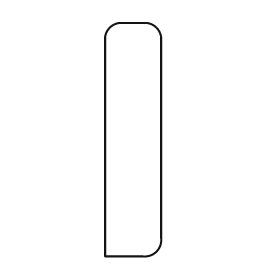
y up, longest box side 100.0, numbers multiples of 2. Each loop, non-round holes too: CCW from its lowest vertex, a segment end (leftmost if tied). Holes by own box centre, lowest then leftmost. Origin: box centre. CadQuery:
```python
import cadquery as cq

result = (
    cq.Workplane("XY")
    .moveTo(-12.0, -50.0)
    .lineTo(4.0, -50.0)
    .threePointArc((10.0, -48.0), (12.0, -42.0))
    .lineTo(12.0, 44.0)
    .threePointArc((10.0, 48.0), (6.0, 50.0))
    .lineTo(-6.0, 50.0)
    .threePointArc((-10.0, 48.0), (-12.0, 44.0))
    .close()
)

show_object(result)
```